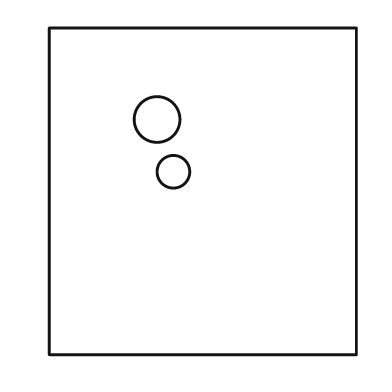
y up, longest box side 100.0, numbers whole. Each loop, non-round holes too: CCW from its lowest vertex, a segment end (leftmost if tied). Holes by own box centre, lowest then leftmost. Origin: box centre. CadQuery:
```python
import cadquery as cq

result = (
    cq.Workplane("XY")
    .moveTo(-47.0, -50.0)
    .lineTo(47.0, -50.0)
    .lineTo(47.0, 50.0)
    .lineTo(-47.0, 50.0)
    .close()
    .moveTo(-9.0, 6.0)
    .circle(5.0)
    .moveTo(-14.0, 22.0)
    .circle(7.0)
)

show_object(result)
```